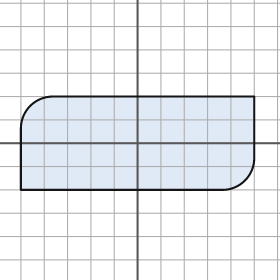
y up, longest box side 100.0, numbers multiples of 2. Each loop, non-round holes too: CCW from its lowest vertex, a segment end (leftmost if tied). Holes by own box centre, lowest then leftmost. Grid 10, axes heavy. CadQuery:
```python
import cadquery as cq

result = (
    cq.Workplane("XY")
    .moveTo(-50.0, -20.0)
    .lineTo(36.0, -20.0)
    .threePointArc((46.0, -16.0), (50.0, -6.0))
    .lineTo(50.0, 20.0)
    .lineTo(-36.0, 20.0)
    .threePointArc((-46.0, 16.0), (-50.0, 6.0))
    .close()
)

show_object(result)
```